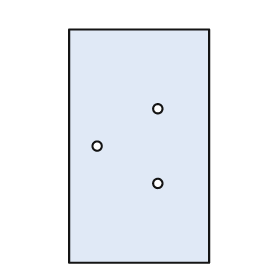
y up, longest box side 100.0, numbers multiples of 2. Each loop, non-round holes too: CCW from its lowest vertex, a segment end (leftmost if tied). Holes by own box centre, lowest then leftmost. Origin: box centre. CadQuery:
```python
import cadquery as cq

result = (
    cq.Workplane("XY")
    .moveTo(-30.0, -50.0)
    .lineTo(30.0, -50.0)
    .lineTo(30.0, 50.0)
    .lineTo(-30.0, 50.0)
    .close()
    .moveTo(8.0, -16.0)
    .circle(2.0)
    .moveTo(-18.0, 0.0)
    .circle(2.0)
    .moveTo(8.0, 16.0)
    .circle(2.0)
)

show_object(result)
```